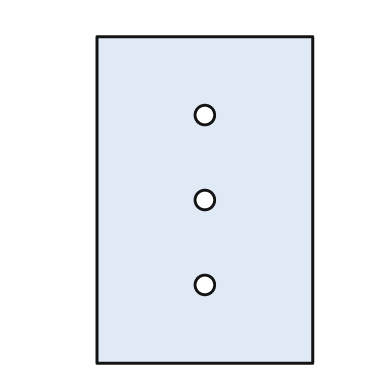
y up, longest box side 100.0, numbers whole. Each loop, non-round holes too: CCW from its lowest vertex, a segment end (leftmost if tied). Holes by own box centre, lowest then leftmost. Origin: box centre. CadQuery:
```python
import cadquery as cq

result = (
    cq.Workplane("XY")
    .moveTo(-33.0, -50.0)
    .lineTo(33.0, -50.0)
    .lineTo(33.0, 50.0)
    .lineTo(-33.0, 50.0)
    .close()
    .moveTo(0.0, -26.0)
    .circle(3.0)
    .moveTo(0.0, 0.0)
    .circle(3.0)
    .moveTo(0.0, 26.0)
    .circle(3.0)
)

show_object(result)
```